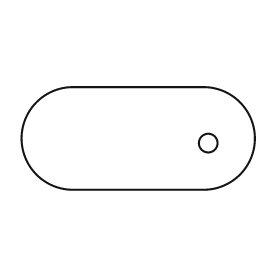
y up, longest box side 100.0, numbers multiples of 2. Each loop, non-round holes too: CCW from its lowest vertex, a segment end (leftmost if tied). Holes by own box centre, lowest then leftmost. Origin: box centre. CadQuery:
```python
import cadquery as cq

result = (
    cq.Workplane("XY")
    .moveTo(-28.0, -22.0)
    .lineTo(28.0, -22.0)
    .threePointArc((50.0, 0.0), (28.0, 22.0))
    .lineTo(-28.0, 22.0)
    .threePointArc((-50.0, 0.0), (-28.0, -22.0))
    .close()
    .moveTo(30.0, -2.0)
    .circle(4.0)
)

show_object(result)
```